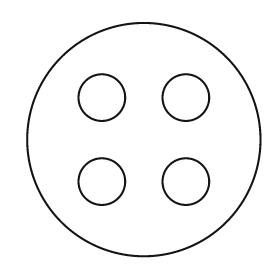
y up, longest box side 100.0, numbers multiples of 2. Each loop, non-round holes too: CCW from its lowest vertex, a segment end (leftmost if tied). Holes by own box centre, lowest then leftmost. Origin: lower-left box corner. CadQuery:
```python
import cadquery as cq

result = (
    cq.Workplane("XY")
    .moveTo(50.0, 50.0)
    .circle(50.0)
    .moveTo(32.0, 32.0)
    .circle(10.0)
    .moveTo(68.0, 32.0)
    .circle(10.0)
    .moveTo(32.0, 68.0)
    .circle(10.0)
    .moveTo(68.0, 68.0)
    .circle(10.0)
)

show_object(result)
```